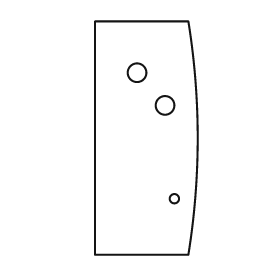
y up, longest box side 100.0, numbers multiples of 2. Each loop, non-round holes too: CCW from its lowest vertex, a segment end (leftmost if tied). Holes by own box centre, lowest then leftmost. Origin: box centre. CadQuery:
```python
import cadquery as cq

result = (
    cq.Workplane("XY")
    .moveTo(-22.0, -50.0)
    .lineTo(18.0, -50.0)
    .threePointArc((22.0, 0.0), (18.0, 50.0))
    .lineTo(-22.0, 50.0)
    .close()
    .moveTo(12.0, -26.0)
    .circle(2.0)
    .moveTo(8.0, 14.0)
    .circle(4.0)
    .moveTo(-4.0, 28.0)
    .circle(4.0)
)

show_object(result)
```